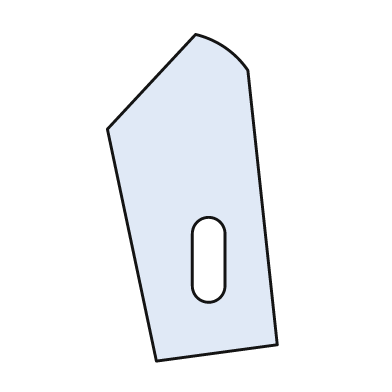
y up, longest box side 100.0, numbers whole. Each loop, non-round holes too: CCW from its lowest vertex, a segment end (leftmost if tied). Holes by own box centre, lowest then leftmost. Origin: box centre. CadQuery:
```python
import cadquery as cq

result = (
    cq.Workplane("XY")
    .moveTo(-11.0, -50.0)
    .lineTo(26.0, -45.0)
    .lineTo(17.0, 39.0)
    .threePointArc((10.0, 46.0), (1.0, 50.0))
    .lineTo(-26.0, 21.0)
    .close()
    .moveTo(0.0, -27.0)
    .threePointArc((5.0, -32.0), (10.0, -27.0))
    .lineTo(10.0, -11.0)
    .threePointArc((5.0, -6.0), (0.0, -11.0))
    .close()
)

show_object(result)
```